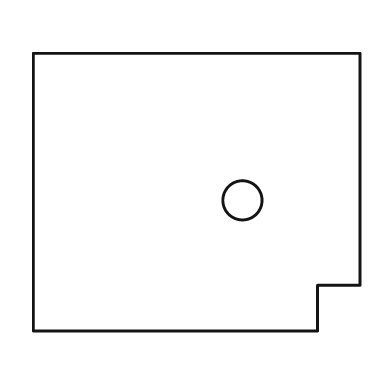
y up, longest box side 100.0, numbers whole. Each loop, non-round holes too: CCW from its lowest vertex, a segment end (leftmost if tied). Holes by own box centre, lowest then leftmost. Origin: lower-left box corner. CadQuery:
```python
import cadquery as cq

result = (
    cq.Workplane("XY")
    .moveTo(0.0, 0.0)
    .lineTo(87.0, 0.0)
    .lineTo(87.0, 14.0)
    .lineTo(100.0, 14.0)
    .lineTo(100.0, 85.0)
    .lineTo(0.0, 85.0)
    .close()
    .moveTo(64.0, 40.0)
    .circle(6.0)
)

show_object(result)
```